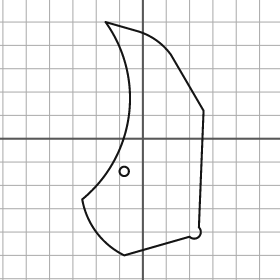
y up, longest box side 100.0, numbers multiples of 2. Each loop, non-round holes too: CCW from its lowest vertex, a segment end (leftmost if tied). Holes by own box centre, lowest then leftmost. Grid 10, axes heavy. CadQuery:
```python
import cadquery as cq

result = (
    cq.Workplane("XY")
    .moveTo(-8.0, -50.0)
    .lineTo(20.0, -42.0)
    .threePointArc((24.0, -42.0), (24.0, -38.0))
    .lineTo(26.0, 12.0)
    .lineTo(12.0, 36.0)
    .threePointArc((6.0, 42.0), (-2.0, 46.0))
    .lineTo(-16.0, 50.0)
    .threePointArc((-6.0, 10.0), (-26.0, -26.0))
    .threePointArc((-20.0, -40.0), (-8.0, -50.0))
    .close()
    .moveTo(-8.0, -14.0)
    .circle(2.0)
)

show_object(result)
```